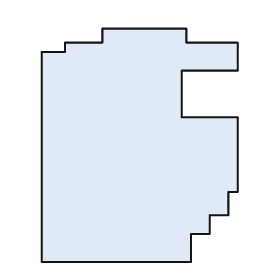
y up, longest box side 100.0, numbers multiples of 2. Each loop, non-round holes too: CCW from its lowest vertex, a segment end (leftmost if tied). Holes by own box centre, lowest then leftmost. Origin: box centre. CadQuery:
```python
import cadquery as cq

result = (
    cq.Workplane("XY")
    .moveTo(-42.0, -50.0)
    .lineTo(22.0, -50.0)
    .lineTo(22.0, -38.0)
    .lineTo(30.0, -38.0)
    .lineTo(30.0, -30.0)
    .lineTo(38.0, -30.0)
    .lineTo(38.0, -20.0)
    .lineTo(42.0, -20.0)
    .lineTo(42.0, 12.0)
    .lineTo(18.0, 12.0)
    .lineTo(18.0, 32.0)
    .lineTo(42.0, 32.0)
    .lineTo(42.0, 44.0)
    .lineTo(20.0, 44.0)
    .lineTo(20.0, 50.0)
    .lineTo(-16.0, 50.0)
    .lineTo(-16.0, 44.0)
    .lineTo(-32.0, 44.0)
    .lineTo(-32.0, 40.0)
    .lineTo(-42.0, 40.0)
    .close()
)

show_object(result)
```